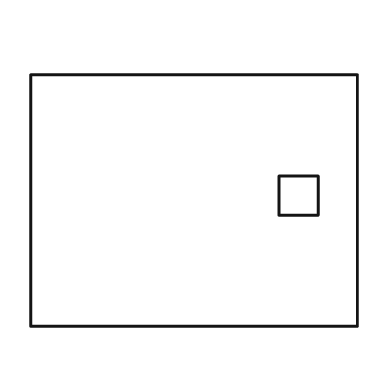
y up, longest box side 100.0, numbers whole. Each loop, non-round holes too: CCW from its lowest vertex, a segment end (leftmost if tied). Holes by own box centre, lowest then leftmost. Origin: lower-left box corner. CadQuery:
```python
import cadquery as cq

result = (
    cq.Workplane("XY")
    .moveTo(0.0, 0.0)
    .lineTo(100.0, 0.0)
    .lineTo(100.0, 77.0)
    .lineTo(0.0, 77.0)
    .close()
    .moveTo(76.0, 34.0)
    .lineTo(88.0, 34.0)
    .lineTo(88.0, 46.0)
    .lineTo(76.0, 46.0)
    .close()
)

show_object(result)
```